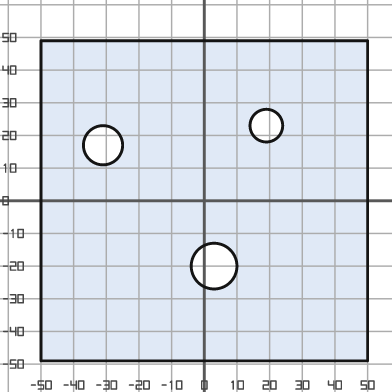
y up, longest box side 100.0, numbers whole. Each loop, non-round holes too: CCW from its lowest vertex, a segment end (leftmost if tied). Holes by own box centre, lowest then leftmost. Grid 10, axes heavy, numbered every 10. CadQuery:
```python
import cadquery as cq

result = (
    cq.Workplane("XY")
    .moveTo(-50.0, -49.0)
    .lineTo(50.0, -49.0)
    .lineTo(50.0, 49.0)
    .lineTo(-50.0, 49.0)
    .close()
    .moveTo(3.0, -20.0)
    .circle(7.0)
    .moveTo(-31.0, 17.0)
    .circle(6.0)
    .moveTo(19.0, 23.0)
    .circle(5.0)
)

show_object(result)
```